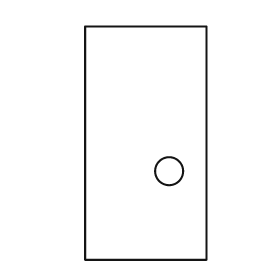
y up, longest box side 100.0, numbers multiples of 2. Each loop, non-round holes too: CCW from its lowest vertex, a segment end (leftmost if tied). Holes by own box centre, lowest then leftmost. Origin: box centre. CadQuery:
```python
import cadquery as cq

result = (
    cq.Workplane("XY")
    .moveTo(-26.0, -50.0)
    .lineTo(26.0, -50.0)
    .lineTo(26.0, 50.0)
    .lineTo(-26.0, 50.0)
    .close()
    .moveTo(10.0, -12.0)
    .circle(6.0)
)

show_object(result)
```